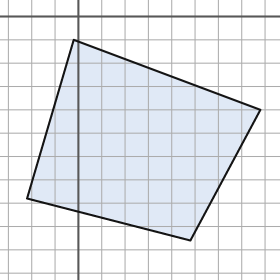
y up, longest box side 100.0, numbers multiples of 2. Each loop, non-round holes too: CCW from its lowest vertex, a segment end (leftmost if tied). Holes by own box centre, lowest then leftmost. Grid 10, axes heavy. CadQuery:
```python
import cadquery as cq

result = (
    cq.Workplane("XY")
    .moveTo(48.0, -96.0)
    .lineTo(78.0, -40.0)
    .lineTo(-2.0, -10.0)
    .lineTo(-22.0, -78.0)
    .close()
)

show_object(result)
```